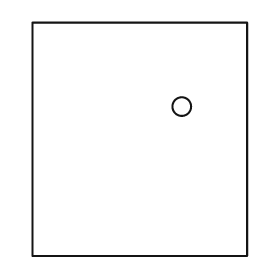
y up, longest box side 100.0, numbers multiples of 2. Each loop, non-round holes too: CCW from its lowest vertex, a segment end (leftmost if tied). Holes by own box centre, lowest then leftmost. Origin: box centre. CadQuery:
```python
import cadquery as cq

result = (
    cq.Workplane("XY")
    .moveTo(-46.0, -50.0)
    .lineTo(46.0, -50.0)
    .lineTo(46.0, 50.0)
    .lineTo(-46.0, 50.0)
    .close()
    .moveTo(18.0, 14.0)
    .circle(4.0)
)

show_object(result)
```